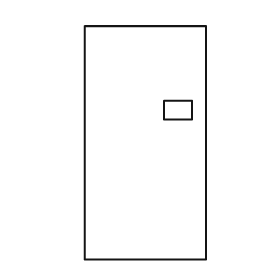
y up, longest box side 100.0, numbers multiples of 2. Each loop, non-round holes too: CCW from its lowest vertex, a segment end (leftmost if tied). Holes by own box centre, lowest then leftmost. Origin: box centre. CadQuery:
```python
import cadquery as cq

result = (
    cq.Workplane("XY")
    .moveTo(-26.0, -50.0)
    .lineTo(26.0, -50.0)
    .lineTo(26.0, 50.0)
    .lineTo(-26.0, 50.0)
    .close()
    .moveTo(8.0, 10.0)
    .lineTo(20.0, 10.0)
    .lineTo(20.0, 18.0)
    .lineTo(8.0, 18.0)
    .close()
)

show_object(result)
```